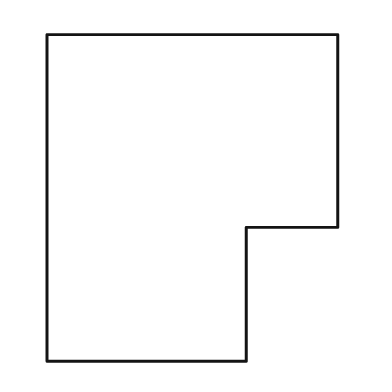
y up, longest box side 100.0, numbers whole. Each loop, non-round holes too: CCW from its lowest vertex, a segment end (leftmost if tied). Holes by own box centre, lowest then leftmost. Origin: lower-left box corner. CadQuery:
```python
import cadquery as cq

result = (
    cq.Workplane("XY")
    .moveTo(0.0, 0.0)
    .lineTo(61.0, 0.0)
    .lineTo(61.0, 41.0)
    .lineTo(89.0, 41.0)
    .lineTo(89.0, 100.0)
    .lineTo(0.0, 100.0)
    .close()
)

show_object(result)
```